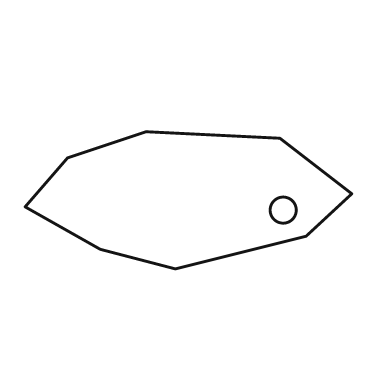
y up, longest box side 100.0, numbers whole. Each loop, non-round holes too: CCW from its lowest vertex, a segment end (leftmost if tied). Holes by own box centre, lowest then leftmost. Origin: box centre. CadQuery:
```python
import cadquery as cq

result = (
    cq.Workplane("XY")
    .moveTo(-4.0, -21.0)
    .lineTo(36.0, -11.0)
    .lineTo(50.0, 2.0)
    .lineTo(28.0, 19.0)
    .lineTo(-13.0, 21.0)
    .lineTo(-37.0, 13.0)
    .lineTo(-50.0, -2.0)
    .lineTo(-27.0, -15.0)
    .close()
    .moveTo(29.0, -3.0)
    .circle(4.0)
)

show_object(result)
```